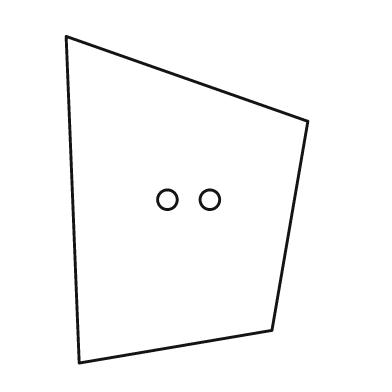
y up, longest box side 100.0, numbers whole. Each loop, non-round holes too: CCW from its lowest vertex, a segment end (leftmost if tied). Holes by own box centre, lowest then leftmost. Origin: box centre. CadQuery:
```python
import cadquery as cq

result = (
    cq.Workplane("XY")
    .moveTo(-33.0, -50.0)
    .lineTo(26.0, -40.0)
    .lineTo(37.0, 24.0)
    .lineTo(-37.0, 50.0)
    .close()
    .moveTo(-6.0, 0.0)
    .circle(3.0)
    .moveTo(7.0, 0.0)
    .circle(3.0)
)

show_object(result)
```